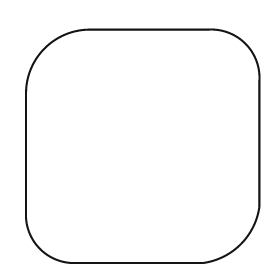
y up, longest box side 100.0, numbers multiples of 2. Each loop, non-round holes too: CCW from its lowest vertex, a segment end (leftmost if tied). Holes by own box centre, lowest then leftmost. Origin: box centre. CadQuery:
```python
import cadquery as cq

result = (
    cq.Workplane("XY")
    .moveTo(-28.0, -50.0)
    .lineTo(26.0, -50.0)
    .threePointArc((42.0, -42.0), (50.0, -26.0))
    .lineTo(50.0, 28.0)
    .threePointArc((44.0, 44.0), (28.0, 50.0))
    .lineTo(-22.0, 50.0)
    .threePointArc((-42.0, 42.0), (-50.0, 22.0))
    .lineTo(-50.0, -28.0)
    .threePointArc((-44.0, -44.0), (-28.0, -50.0))
    .close()
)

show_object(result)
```